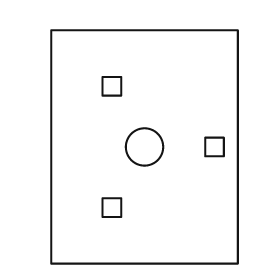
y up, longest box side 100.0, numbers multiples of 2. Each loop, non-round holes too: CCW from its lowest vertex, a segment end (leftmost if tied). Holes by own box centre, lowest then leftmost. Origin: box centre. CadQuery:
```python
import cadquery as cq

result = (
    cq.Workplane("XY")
    .moveTo(-40.0, -50.0)
    .lineTo(40.0, -50.0)
    .lineTo(40.0, 50.0)
    .lineTo(-40.0, 50.0)
    .close()
    .moveTo(-18.0, -30.0)
    .lineTo(-10.0, -30.0)
    .lineTo(-10.0, -22.0)
    .lineTo(-18.0, -22.0)
    .close()
    .moveTo(0.0, 0.0)
    .circle(8.0)
    .moveTo(26.0, -4.0)
    .lineTo(34.0, -4.0)
    .lineTo(34.0, 4.0)
    .lineTo(26.0, 4.0)
    .close()
    .moveTo(-18.0, 22.0)
    .lineTo(-10.0, 22.0)
    .lineTo(-10.0, 30.0)
    .lineTo(-18.0, 30.0)
    .close()
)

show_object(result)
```